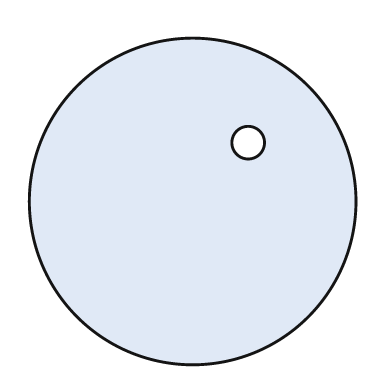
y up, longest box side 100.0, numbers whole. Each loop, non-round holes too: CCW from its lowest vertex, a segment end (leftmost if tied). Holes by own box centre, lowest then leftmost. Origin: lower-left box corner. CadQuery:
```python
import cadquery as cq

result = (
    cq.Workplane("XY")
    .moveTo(50.0, 50.0)
    .circle(50.0)
    .moveTo(67.0, 68.0)
    .circle(5.0)
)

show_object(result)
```